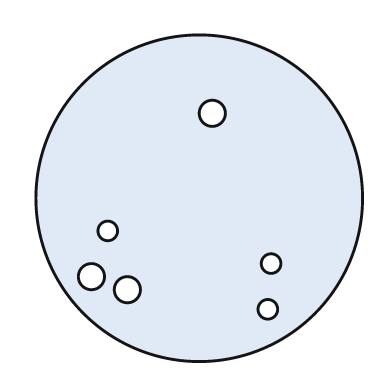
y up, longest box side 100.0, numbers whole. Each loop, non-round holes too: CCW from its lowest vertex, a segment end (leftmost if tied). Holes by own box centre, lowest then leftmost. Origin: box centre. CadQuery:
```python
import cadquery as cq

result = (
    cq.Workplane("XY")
    .moveTo(0.0, 0.0)
    .circle(50.0)
    .moveTo(21.0, -34.0)
    .circle(3.0)
    .moveTo(-22.0, -28.0)
    .circle(4.0)
    .moveTo(-33.0, -24.0)
    .circle(4.0)
    .moveTo(22.0, -20.0)
    .circle(3.0)
    .moveTo(-28.0, -10.0)
    .circle(3.0)
    .moveTo(4.0, 26.0)
    .circle(4.0)
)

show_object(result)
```